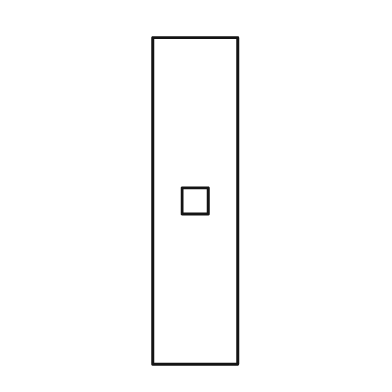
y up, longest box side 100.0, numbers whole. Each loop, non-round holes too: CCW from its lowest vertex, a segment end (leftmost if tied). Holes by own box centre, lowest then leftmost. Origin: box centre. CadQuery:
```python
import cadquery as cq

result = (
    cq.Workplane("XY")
    .moveTo(-13.0, -50.0)
    .lineTo(13.0, -50.0)
    .lineTo(13.0, 50.0)
    .lineTo(-13.0, 50.0)
    .close()
    .moveTo(-4.0, -4.0)
    .lineTo(4.0, -4.0)
    .lineTo(4.0, 4.0)
    .lineTo(-4.0, 4.0)
    .close()
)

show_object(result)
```